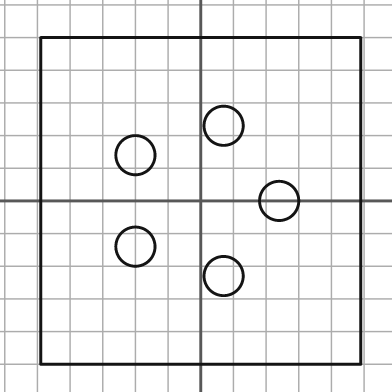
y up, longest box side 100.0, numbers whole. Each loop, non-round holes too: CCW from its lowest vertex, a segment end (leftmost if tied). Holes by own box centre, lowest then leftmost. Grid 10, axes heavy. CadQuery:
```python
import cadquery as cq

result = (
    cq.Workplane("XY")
    .moveTo(-49.0, -50.0)
    .lineTo(49.0, -50.0)
    .lineTo(49.0, 50.0)
    .lineTo(-49.0, 50.0)
    .close()
    .moveTo(7.0, -23.0)
    .circle(6.0)
    .moveTo(-20.0, -14.0)
    .circle(6.0)
    .moveTo(24.0, 0.0)
    .circle(6.0)
    .moveTo(-20.0, 14.0)
    .circle(6.0)
    .moveTo(7.0, 23.0)
    .circle(6.0)
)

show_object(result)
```